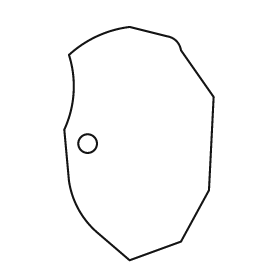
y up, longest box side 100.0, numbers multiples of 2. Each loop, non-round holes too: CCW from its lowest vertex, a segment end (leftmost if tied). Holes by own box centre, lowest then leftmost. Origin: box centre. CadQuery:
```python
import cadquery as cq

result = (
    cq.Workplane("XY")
    .moveTo(-4.0, -50.0)
    .lineTo(18.0, -42.0)
    .lineTo(30.0, -20.0)
    .lineTo(32.0, 20.0)
    .lineTo(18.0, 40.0)
    .threePointArc((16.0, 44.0), (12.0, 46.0))
    .lineTo(-4.0, 50.0)
    .threePointArc((-18.0, 46.0), (-30.0, 38.0))
    .threePointArc((-28.0, 22.0), (-32.0, 6.0))
    .lineTo(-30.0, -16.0)
    .threePointArc((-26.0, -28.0), (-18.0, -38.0))
    .close()
    .moveTo(-22.0, 0.0)
    .circle(4.0)
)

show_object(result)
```